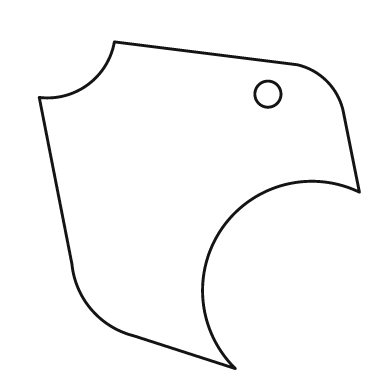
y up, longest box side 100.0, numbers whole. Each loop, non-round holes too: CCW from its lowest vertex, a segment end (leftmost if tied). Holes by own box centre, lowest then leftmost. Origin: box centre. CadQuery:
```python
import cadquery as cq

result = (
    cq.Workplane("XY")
    .moveTo(11.0, -50.0)
    .threePointArc((7.0, -7.0), (49.0, 4.0))
    .lineTo(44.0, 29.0)
    .threePointArc((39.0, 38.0), (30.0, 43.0))
    .lineTo(-26.0, 50.0)
    .threePointArc((-34.0, 37.0), (-49.0, 33.0))
    .lineTo(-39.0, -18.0)
    .threePointArc((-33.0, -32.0), (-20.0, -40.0))
    .close()
    .moveTo(21.0, 34.0)
    .circle(4.0)
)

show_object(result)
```